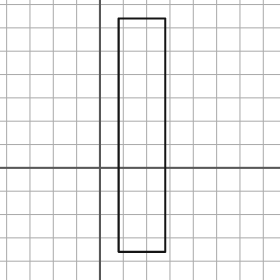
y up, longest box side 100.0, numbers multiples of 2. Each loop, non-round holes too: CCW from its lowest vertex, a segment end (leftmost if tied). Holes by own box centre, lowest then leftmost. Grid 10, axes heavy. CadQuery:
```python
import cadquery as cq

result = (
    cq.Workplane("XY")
    .moveTo(8.0, -36.0)
    .lineTo(28.0, -36.0)
    .lineTo(28.0, 64.0)
    .lineTo(8.0, 64.0)
    .close()
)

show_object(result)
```